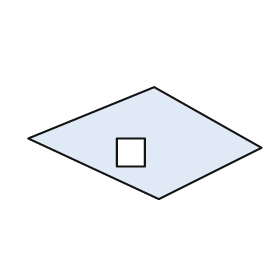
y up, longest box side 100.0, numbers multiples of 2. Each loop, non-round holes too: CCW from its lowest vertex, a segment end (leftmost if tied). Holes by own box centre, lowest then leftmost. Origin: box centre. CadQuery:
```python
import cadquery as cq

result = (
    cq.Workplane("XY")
    .moveTo(6.0, -24.0)
    .lineTo(50.0, -2.0)
    .lineTo(4.0, 24.0)
    .lineTo(-50.0, 2.0)
    .close()
    .moveTo(-12.0, -10.0)
    .lineTo(0.0, -10.0)
    .lineTo(0.0, 2.0)
    .lineTo(-12.0, 2.0)
    .close()
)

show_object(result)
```